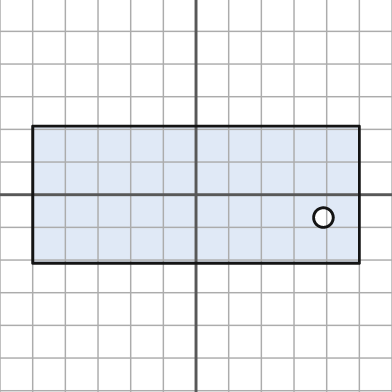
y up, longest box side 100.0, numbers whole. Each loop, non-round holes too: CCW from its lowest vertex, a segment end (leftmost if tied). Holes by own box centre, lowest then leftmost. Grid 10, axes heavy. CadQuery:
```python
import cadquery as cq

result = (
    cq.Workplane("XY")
    .moveTo(-50.0, -21.0)
    .lineTo(50.0, -21.0)
    .lineTo(50.0, 21.0)
    .lineTo(-50.0, 21.0)
    .close()
    .moveTo(39.0, -7.0)
    .circle(3.0)
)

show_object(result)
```